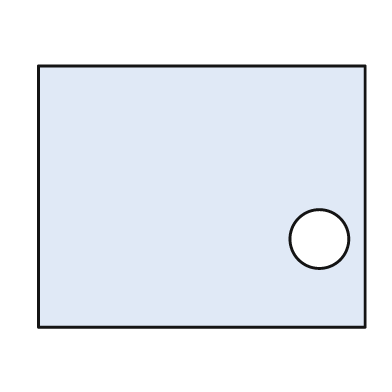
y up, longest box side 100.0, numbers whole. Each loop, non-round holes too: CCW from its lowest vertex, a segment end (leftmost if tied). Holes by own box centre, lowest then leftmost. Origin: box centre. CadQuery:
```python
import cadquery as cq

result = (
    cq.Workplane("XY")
    .moveTo(-50.0, -40.0)
    .lineTo(50.0, -40.0)
    .lineTo(50.0, 40.0)
    .lineTo(-50.0, 40.0)
    .close()
    .moveTo(36.0, -13.0)
    .circle(9.0)
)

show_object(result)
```